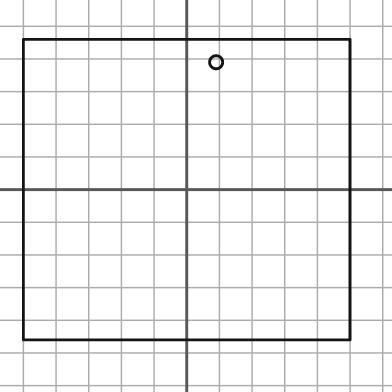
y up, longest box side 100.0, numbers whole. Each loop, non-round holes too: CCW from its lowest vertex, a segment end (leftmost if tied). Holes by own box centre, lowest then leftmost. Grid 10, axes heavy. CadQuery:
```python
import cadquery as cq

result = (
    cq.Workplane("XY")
    .moveTo(-50.0, -46.0)
    .lineTo(50.0, -46.0)
    .lineTo(50.0, 46.0)
    .lineTo(-50.0, 46.0)
    .close()
    .moveTo(9.0, 39.0)
    .circle(2.0)
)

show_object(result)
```